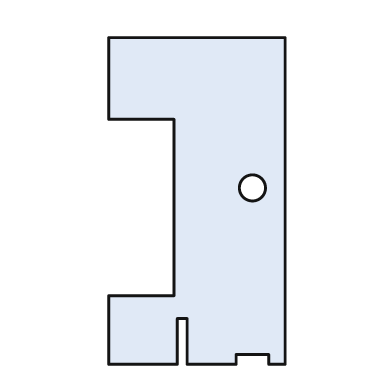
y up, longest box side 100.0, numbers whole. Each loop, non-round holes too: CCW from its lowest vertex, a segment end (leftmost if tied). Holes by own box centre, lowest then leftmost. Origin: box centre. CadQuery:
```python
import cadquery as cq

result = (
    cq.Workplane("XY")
    .moveTo(-27.0, -50.0)
    .lineTo(-6.0, -50.0)
    .lineTo(-6.0, -36.0)
    .lineTo(-3.0, -36.0)
    .lineTo(-3.0, -50.0)
    .lineTo(12.0, -50.0)
    .lineTo(12.0, -47.0)
    .lineTo(22.0, -47.0)
    .lineTo(22.0, -50.0)
    .lineTo(27.0, -50.0)
    .lineTo(27.0, 50.0)
    .lineTo(-27.0, 50.0)
    .lineTo(-27.0, 25.0)
    .lineTo(-7.0, 25.0)
    .lineTo(-7.0, -29.0)
    .lineTo(-27.0, -29.0)
    .close()
    .moveTo(17.0, 4.0)
    .circle(4.0)
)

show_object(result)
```